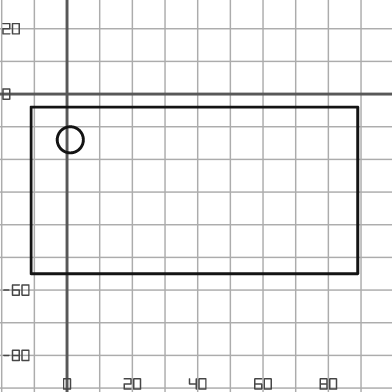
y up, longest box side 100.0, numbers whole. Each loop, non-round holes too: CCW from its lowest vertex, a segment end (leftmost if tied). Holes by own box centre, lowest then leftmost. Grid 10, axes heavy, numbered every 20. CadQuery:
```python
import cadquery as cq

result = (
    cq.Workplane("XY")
    .moveTo(-11.0, -55.0)
    .lineTo(89.0, -55.0)
    .lineTo(89.0, -4.0)
    .lineTo(-11.0, -4.0)
    .close()
    .moveTo(1.0, -14.0)
    .circle(4.0)
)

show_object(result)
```